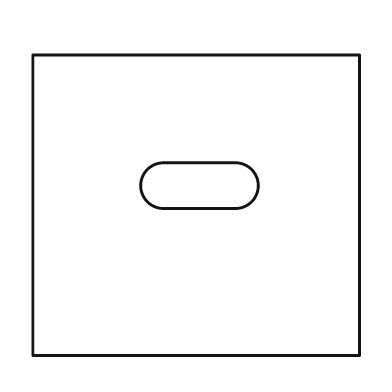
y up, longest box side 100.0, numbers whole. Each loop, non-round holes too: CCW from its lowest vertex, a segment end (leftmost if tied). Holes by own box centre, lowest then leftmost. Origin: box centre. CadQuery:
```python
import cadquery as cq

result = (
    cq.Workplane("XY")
    .moveTo(-50.0, -46.0)
    .lineTo(50.0, -46.0)
    .lineTo(50.0, 46.0)
    .lineTo(-50.0, 46.0)
    .close()
    .moveTo(-10.0, -1.0)
    .lineTo(12.0, -1.0)
    .threePointArc((19.0, 6.0), (12.0, 13.0))
    .lineTo(-10.0, 13.0)
    .threePointArc((-17.0, 6.0), (-10.0, -1.0))
    .close()
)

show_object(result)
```